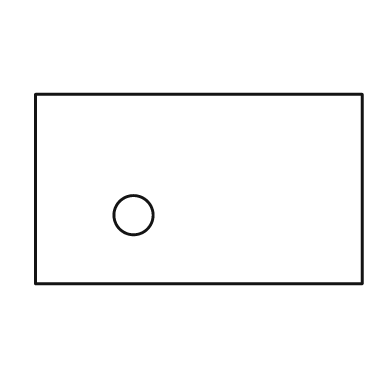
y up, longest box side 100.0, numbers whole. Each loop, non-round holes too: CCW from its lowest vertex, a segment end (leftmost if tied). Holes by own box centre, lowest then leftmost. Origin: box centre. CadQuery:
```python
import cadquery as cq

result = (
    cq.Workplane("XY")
    .moveTo(-50.0, -29.0)
    .lineTo(50.0, -29.0)
    .lineTo(50.0, 29.0)
    .lineTo(-50.0, 29.0)
    .close()
    .moveTo(-20.0, -8.0)
    .circle(6.0)
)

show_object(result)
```